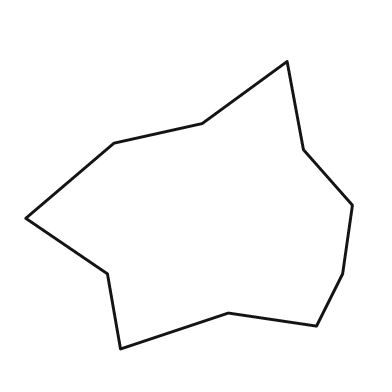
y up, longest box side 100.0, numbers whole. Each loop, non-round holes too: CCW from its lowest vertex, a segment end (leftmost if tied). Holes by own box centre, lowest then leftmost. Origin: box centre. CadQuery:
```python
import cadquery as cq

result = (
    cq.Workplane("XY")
    .moveTo(-21.0, -44.0)
    .lineTo(12.0, -33.0)
    .lineTo(39.0, -37.0)
    .lineTo(47.0, -21.0)
    .lineTo(50.0, 0.0)
    .lineTo(35.0, 17.0)
    .lineTo(30.0, 44.0)
    .lineTo(4.0, 25.0)
    .lineTo(-23.0, 19.0)
    .lineTo(-50.0, -4.0)
    .lineTo(-25.0, -21.0)
    .close()
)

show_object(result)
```